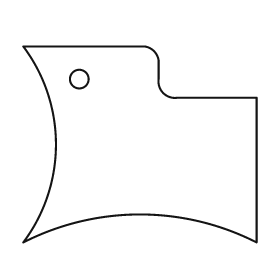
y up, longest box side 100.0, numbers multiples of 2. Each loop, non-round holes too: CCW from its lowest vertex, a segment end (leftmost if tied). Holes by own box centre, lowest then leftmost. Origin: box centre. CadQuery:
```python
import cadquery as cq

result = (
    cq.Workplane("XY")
    .moveTo(-50.0, -42.0)
    .threePointArc((0.0, -30.0), (50.0, -42.0))
    .lineTo(50.0, 20.0)
    .lineTo(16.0, 20.0)
    .threePointArc((10.0, 22.0), (8.0, 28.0))
    .lineTo(8.0, 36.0)
    .threePointArc((6.0, 40.0), (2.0, 42.0))
    .lineTo(-50.0, 42.0)
    .threePointArc((-36.0, 0.0), (-50.0, -42.0))
    .close()
    .moveTo(-26.0, 28.0)
    .circle(4.0)
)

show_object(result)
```